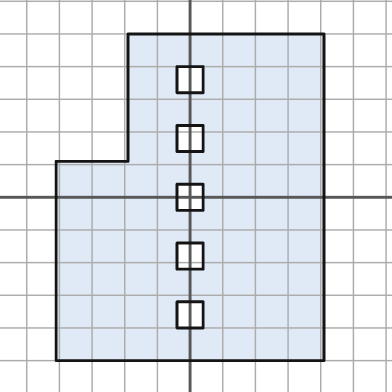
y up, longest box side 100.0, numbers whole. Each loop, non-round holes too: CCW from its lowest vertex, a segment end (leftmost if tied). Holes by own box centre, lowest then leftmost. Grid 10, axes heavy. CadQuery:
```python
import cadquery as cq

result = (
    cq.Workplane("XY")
    .moveTo(-41.0, -50.0)
    .lineTo(41.0, -50.0)
    .lineTo(41.0, 50.0)
    .lineTo(-19.0, 50.0)
    .lineTo(-19.0, 11.0)
    .lineTo(-41.0, 11.0)
    .close()
    .moveTo(-4.0, -40.0)
    .lineTo(4.0, -40.0)
    .lineTo(4.0, -32.0)
    .lineTo(-4.0, -32.0)
    .close()
    .moveTo(-4.0, -22.0)
    .lineTo(4.0, -22.0)
    .lineTo(4.0, -14.0)
    .lineTo(-4.0, -14.0)
    .close()
    .moveTo(-4.0, -4.0)
    .lineTo(4.0, -4.0)
    .lineTo(4.0, 4.0)
    .lineTo(-4.0, 4.0)
    .close()
    .moveTo(-4.0, 14.0)
    .lineTo(4.0, 14.0)
    .lineTo(4.0, 22.0)
    .lineTo(-4.0, 22.0)
    .close()
    .moveTo(-4.0, 32.0)
    .lineTo(4.0, 32.0)
    .lineTo(4.0, 40.0)
    .lineTo(-4.0, 40.0)
    .close()
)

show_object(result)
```